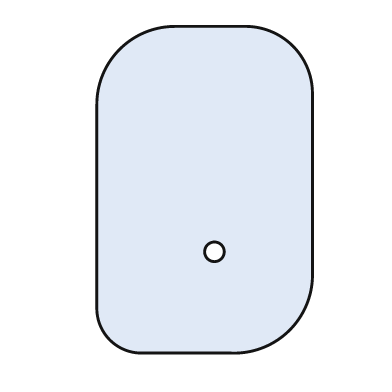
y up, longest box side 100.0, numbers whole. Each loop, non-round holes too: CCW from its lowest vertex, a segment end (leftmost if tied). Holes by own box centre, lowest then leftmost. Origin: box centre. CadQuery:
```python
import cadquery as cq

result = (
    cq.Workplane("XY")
    .moveTo(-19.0, -50.0)
    .lineTo(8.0, -50.0)
    .threePointArc((26.0, -43.0), (33.0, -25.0))
    .lineTo(33.0, 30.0)
    .threePointArc((27.0, 44.0), (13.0, 50.0))
    .lineTo(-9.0, 50.0)
    .threePointArc((-26.0, 43.0), (-33.0, 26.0))
    .lineTo(-33.0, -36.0)
    .threePointArc((-29.0, -46.0), (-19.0, -50.0))
    .close()
    .moveTo(3.0, -19.0)
    .circle(3.0)
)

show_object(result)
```